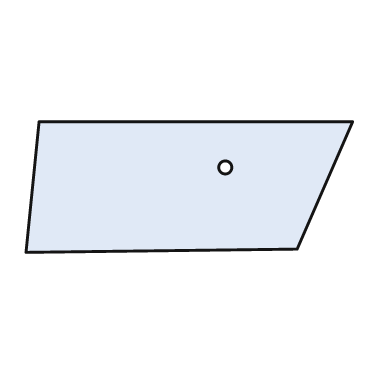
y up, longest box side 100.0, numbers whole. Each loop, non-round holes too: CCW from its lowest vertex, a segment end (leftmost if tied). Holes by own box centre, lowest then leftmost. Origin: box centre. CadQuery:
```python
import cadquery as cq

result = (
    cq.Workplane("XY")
    .moveTo(-50.0, -20.0)
    .lineTo(33.0, -19.0)
    .lineTo(50.0, 20.0)
    .lineTo(-46.0, 20.0)
    .close()
    .moveTo(11.0, 6.0)
    .circle(2.0)
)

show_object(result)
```